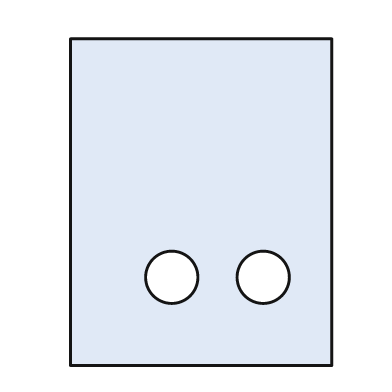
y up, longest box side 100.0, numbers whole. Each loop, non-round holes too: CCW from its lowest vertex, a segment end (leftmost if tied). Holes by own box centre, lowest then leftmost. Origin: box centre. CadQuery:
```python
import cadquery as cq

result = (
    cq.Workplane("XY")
    .moveTo(-40.0, -50.0)
    .lineTo(40.0, -50.0)
    .lineTo(40.0, 50.0)
    .lineTo(-40.0, 50.0)
    .close()
    .moveTo(-9.0, -23.0)
    .circle(8.0)
    .moveTo(19.0, -23.0)
    .circle(8.0)
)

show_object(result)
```